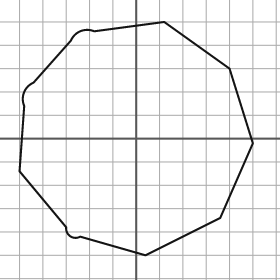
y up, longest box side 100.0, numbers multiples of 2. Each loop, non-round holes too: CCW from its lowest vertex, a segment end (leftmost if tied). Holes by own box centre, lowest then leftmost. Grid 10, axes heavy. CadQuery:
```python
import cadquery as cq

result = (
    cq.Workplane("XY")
    .moveTo(4.0, -50.0)
    .lineTo(36.0, -34.0)
    .lineTo(50.0, -2.0)
    .lineTo(40.0, 30.0)
    .lineTo(12.0, 50.0)
    .lineTo(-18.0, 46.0)
    .threePointArc((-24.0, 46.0), (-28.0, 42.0))
    .lineTo(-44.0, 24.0)
    .threePointArc((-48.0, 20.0), (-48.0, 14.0))
    .lineTo(-50.0, -14.0)
    .lineTo(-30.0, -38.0)
    .threePointArc((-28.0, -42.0), (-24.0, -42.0))
    .close()
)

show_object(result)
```